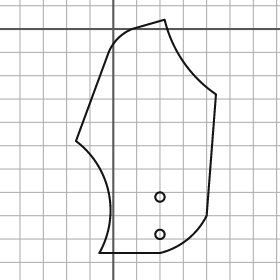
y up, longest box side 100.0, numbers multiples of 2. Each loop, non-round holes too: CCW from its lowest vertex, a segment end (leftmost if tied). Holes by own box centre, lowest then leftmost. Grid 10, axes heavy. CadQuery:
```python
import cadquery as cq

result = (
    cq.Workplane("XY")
    .moveTo(-6.0, -96.0)
    .lineTo(20.0, -96.0)
    .threePointArc((32.0, -90.0), (40.0, -80.0))
    .lineTo(44.0, -28.0)
    .threePointArc((30.0, -14.0), (22.0, 4.0))
    .lineTo(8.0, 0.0)
    .threePointArc((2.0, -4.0), (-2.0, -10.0))
    .lineTo(-16.0, -48.0)
    .threePointArc((-2.0, -70.0), (-6.0, -96.0))
    .close()
    .moveTo(20.0, -88.0)
    .circle(2.0)
    .moveTo(20.0, -72.0)
    .circle(2.0)
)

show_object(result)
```